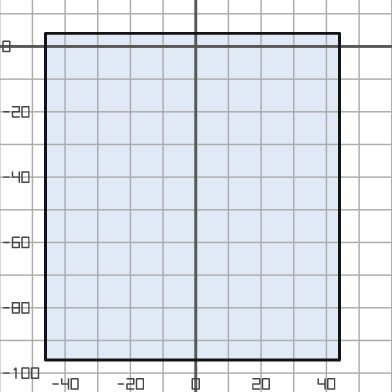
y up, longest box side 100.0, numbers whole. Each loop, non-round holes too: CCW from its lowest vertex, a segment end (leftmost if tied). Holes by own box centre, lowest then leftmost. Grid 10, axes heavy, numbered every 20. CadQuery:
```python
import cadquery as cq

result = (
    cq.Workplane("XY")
    .moveTo(-46.0, -96.0)
    .lineTo(44.0, -96.0)
    .lineTo(44.0, 4.0)
    .lineTo(-46.0, 4.0)
    .close()
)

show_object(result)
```